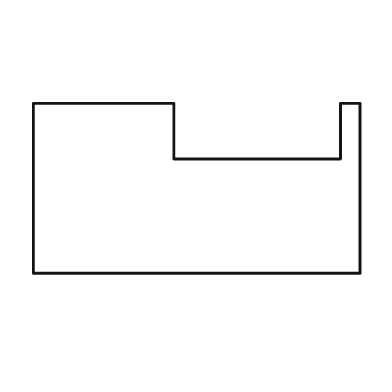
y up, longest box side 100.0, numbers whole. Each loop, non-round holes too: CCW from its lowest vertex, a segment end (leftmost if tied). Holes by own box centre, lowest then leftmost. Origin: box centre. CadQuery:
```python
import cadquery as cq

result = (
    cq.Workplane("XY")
    .moveTo(-50.0, -26.0)
    .lineTo(50.0, -26.0)
    .lineTo(50.0, 26.0)
    .lineTo(44.0, 26.0)
    .lineTo(44.0, 9.0)
    .lineTo(-7.0, 9.0)
    .lineTo(-7.0, 26.0)
    .lineTo(-50.0, 26.0)
    .close()
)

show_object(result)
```